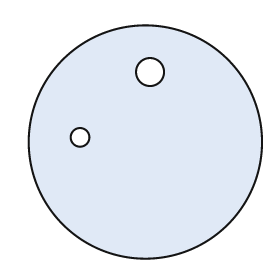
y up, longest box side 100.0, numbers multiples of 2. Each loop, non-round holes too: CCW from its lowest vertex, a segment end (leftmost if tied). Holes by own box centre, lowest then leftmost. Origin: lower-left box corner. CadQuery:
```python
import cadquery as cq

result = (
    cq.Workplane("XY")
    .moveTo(50.0, 50.0)
    .circle(50.0)
    .moveTo(22.0, 52.0)
    .circle(4.0)
    .moveTo(52.0, 80.0)
    .circle(6.0)
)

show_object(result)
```